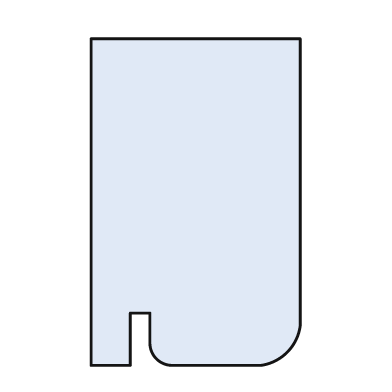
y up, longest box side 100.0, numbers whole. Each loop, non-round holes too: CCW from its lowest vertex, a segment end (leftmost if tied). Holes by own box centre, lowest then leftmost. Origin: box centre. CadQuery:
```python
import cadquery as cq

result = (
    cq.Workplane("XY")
    .moveTo(-32.0, -50.0)
    .lineTo(-20.0, -50.0)
    .lineTo(-20.0, -34.0)
    .lineTo(-14.0, -34.0)
    .lineTo(-14.0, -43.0)
    .threePointArc((-12.0, -48.0), (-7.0, -50.0))
    .lineTo(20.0, -50.0)
    .threePointArc((28.0, -46.0), (32.0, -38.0))
    .lineTo(32.0, 50.0)
    .lineTo(-32.0, 50.0)
    .close()
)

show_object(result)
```